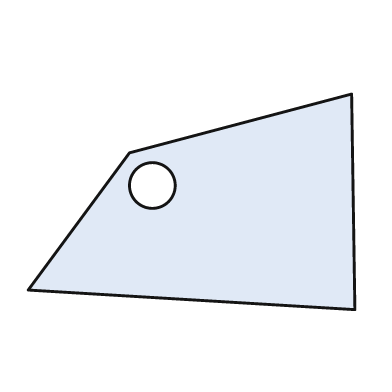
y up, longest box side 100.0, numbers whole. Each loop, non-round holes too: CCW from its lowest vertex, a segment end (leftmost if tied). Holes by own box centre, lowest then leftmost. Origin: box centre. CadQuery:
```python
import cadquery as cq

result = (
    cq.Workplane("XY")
    .moveTo(50.0, -33.0)
    .lineTo(49.0, 33.0)
    .lineTo(-19.0, 15.0)
    .lineTo(-50.0, -27.0)
    .close()
    .moveTo(-12.0, 5.0)
    .circle(7.0)
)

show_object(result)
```